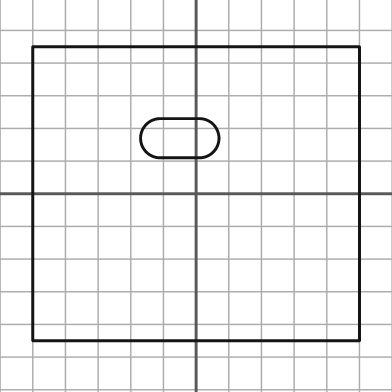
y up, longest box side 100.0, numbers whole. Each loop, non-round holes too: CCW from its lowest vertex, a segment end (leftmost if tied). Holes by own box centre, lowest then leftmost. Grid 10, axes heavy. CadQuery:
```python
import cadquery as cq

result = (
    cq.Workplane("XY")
    .moveTo(-50.0, -45.0)
    .lineTo(50.0, -45.0)
    .lineTo(50.0, 45.0)
    .lineTo(-50.0, 45.0)
    .close()
    .moveTo(-11.0, 11.0)
    .lineTo(1.0, 11.0)
    .threePointArc((7.0, 17.0), (1.0, 23.0))
    .lineTo(-11.0, 23.0)
    .threePointArc((-17.0, 17.0), (-11.0, 11.0))
    .close()
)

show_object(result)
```